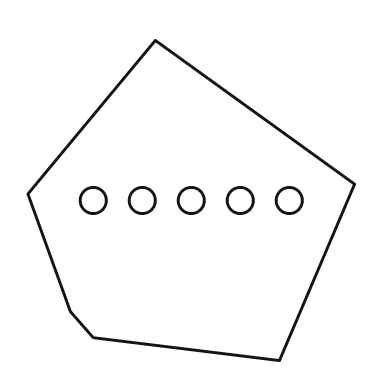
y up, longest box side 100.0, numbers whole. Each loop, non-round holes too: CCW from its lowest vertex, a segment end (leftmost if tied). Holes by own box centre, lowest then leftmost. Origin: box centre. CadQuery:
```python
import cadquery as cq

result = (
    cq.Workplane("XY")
    .moveTo(27.0, -49.0)
    .lineTo(50.0, 5.0)
    .lineTo(-11.0, 49.0)
    .lineTo(-50.0, 2.0)
    .lineTo(-37.0, -34.0)
    .lineTo(-30.0, -42.0)
    .close()
    .moveTo(-30.0, 0.0)
    .circle(4.0)
    .moveTo(-15.0, 0.0)
    .circle(4.0)
    .moveTo(0.0, 0.0)
    .circle(4.0)
    .moveTo(15.0, 0.0)
    .circle(4.0)
    .moveTo(30.0, 0.0)
    .circle(4.0)
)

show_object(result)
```